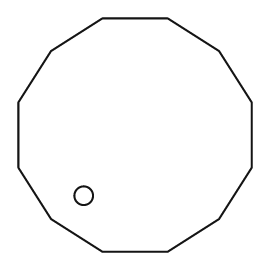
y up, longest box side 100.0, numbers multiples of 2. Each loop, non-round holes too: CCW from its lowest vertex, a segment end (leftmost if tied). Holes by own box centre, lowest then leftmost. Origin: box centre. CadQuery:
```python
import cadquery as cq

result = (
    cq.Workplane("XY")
    .moveTo(-14.0, -50.0)
    .lineTo(14.0, -50.0)
    .lineTo(36.0, -36.0)
    .lineTo(50.0, -14.0)
    .lineTo(50.0, 14.0)
    .lineTo(36.0, 36.0)
    .lineTo(14.0, 50.0)
    .lineTo(-14.0, 50.0)
    .lineTo(-36.0, 36.0)
    .lineTo(-50.0, 14.0)
    .lineTo(-50.0, -14.0)
    .lineTo(-36.0, -36.0)
    .close()
    .moveTo(-22.0, -26.0)
    .circle(4.0)
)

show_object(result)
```